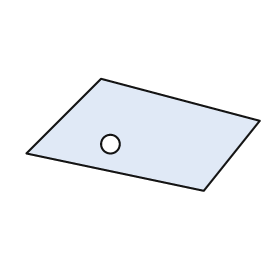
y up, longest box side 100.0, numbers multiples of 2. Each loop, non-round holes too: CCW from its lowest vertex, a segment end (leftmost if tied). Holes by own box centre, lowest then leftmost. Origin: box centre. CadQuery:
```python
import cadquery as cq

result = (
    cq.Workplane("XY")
    .moveTo(26.0, -24.0)
    .lineTo(50.0, 6.0)
    .lineTo(-18.0, 24.0)
    .lineTo(-50.0, -8.0)
    .close()
    .moveTo(-14.0, -4.0)
    .circle(4.0)
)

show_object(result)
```